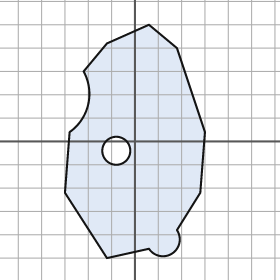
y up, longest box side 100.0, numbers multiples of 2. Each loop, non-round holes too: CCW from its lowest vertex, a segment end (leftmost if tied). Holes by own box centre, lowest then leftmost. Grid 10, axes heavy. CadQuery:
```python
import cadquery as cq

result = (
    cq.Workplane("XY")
    .moveTo(-12.0, -50.0)
    .lineTo(6.0, -46.0)
    .threePointArc((16.0, -48.0), (18.0, -38.0))
    .lineTo(28.0, -22.0)
    .lineTo(30.0, 4.0)
    .lineTo(18.0, 40.0)
    .lineTo(6.0, 50.0)
    .lineTo(-12.0, 42.0)
    .lineTo(-22.0, 30.0)
    .threePointArc((-20.0, 16.0), (-28.0, 4.0))
    .lineTo(-30.0, -22.0)
    .close()
    .moveTo(-8.0, -4.0)
    .circle(6.0)
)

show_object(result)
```